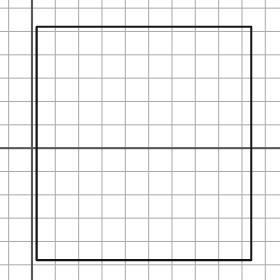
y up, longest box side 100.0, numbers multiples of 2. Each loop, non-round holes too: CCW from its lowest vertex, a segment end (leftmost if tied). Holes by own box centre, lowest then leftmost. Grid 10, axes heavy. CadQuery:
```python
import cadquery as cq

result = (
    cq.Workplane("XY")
    .moveTo(2.0, -48.0)
    .lineTo(94.0, -48.0)
    .lineTo(94.0, 52.0)
    .lineTo(2.0, 52.0)
    .close()
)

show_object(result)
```